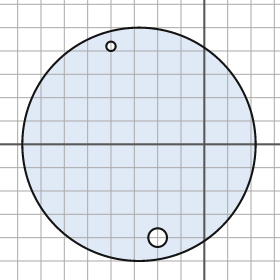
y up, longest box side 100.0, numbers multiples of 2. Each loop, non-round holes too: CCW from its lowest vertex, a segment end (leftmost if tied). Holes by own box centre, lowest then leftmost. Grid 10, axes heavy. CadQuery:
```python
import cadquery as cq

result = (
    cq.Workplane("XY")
    .moveTo(-28.0, 0.0)
    .circle(50.0)
    .moveTo(-20.0, -40.0)
    .circle(4.0)
    .moveTo(-40.0, 42.0)
    .circle(2.0)
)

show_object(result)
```